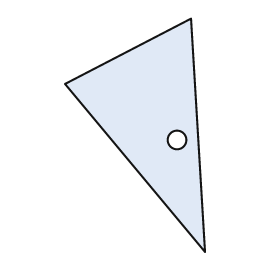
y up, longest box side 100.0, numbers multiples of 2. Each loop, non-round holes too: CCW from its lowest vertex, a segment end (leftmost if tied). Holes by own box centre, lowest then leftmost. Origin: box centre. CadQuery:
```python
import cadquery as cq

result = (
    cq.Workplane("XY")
    .moveTo(30.0, -50.0)
    .lineTo(24.0, 50.0)
    .lineTo(-30.0, 22.0)
    .close()
    .moveTo(18.0, -2.0)
    .circle(4.0)
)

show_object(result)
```